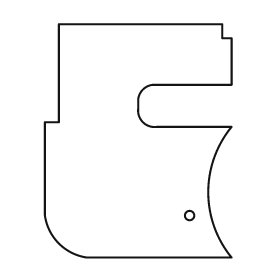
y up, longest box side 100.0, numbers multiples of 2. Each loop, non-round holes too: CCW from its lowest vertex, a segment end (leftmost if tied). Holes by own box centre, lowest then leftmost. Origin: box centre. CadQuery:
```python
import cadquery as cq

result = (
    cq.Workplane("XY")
    .moveTo(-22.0, -50.0)
    .lineTo(40.0, -50.0)
    .threePointArc((30.0, -22.0), (40.0, 6.0))
    .lineTo(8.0, 6.0)
    .threePointArc((2.0, 8.0), (0.0, 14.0))
    .lineTo(0.0, 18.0)
    .threePointArc((2.0, 22.0), (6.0, 24.0))
    .lineTo(40.0, 24.0)
    .lineTo(40.0, 44.0)
    .lineTo(36.0, 44.0)
    .lineTo(36.0, 50.0)
    .lineTo(-34.0, 50.0)
    .lineTo(-34.0, 8.0)
    .lineTo(-40.0, 8.0)
    .lineTo(-40.0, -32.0)
    .threePointArc((-34.0, -44.0), (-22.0, -50.0))
    .close()
    .moveTo(22.0, -32.0)
    .circle(2.0)
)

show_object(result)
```